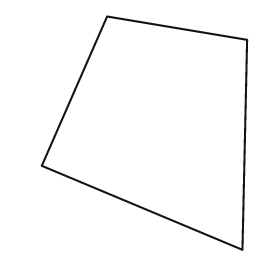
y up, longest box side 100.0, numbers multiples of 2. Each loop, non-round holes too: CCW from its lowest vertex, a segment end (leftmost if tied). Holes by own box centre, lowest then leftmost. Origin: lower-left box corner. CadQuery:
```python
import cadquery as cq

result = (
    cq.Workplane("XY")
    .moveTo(86.0, 0.0)
    .lineTo(88.0, 90.0)
    .lineTo(28.0, 100.0)
    .lineTo(0.0, 36.0)
    .close()
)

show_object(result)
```